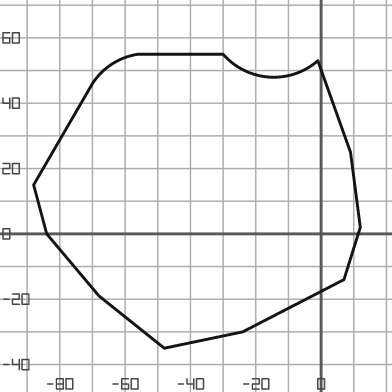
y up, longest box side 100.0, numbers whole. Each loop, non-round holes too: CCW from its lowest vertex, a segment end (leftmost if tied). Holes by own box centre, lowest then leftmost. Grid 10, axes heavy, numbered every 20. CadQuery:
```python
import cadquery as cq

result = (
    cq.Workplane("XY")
    .moveTo(-48.0, -35.0)
    .lineTo(-24.0, -30.0)
    .lineTo(7.0, -14.0)
    .lineTo(12.0, 2.0)
    .lineTo(9.0, 25.0)
    .lineTo(-1.0, 53.0)
    .threePointArc((-16.0, 48.0), (-30.0, 55.0))
    .lineTo(-56.0, 55.0)
    .threePointArc((-64.0, 52.0), (-70.0, 46.0))
    .lineTo(-88.0, 15.0)
    .lineTo(-84.0, 0.0)
    .lineTo(-68.0, -19.0)
    .close()
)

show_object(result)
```